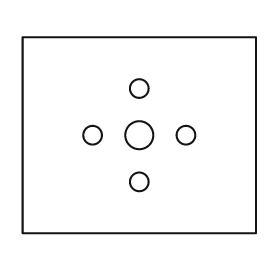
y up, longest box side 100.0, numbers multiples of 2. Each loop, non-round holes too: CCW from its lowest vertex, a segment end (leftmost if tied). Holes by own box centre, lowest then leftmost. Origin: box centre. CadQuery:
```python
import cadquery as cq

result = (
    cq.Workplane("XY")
    .moveTo(-50.0, -42.0)
    .lineTo(50.0, -42.0)
    .lineTo(50.0, 42.0)
    .lineTo(-50.0, 42.0)
    .close()
    .moveTo(0.0, -20.0)
    .circle(4.0)
    .moveTo(-20.0, 0.0)
    .circle(4.0)
    .moveTo(0.0, 0.0)
    .circle(6.0)
    .moveTo(20.0, 0.0)
    .circle(4.0)
    .moveTo(0.0, 20.0)
    .circle(4.0)
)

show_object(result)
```